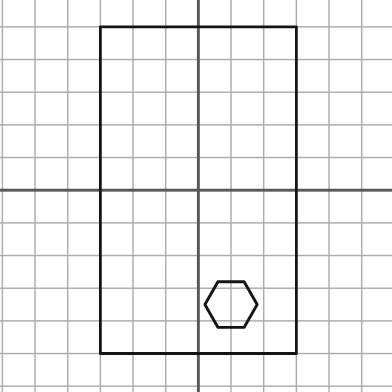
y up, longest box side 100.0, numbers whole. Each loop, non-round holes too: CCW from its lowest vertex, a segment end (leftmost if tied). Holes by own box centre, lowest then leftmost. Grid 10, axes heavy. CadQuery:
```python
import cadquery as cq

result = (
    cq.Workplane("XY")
    .moveTo(-30.0, -50.0)
    .lineTo(30.0, -50.0)
    .lineTo(30.0, 50.0)
    .lineTo(-30.0, 50.0)
    .close()
    .moveTo(6.0, -42.0)
    .lineTo(14.0, -42.0)
    .lineTo(18.0, -35.0)
    .lineTo(14.0, -28.0)
    .lineTo(6.0, -28.0)
    .lineTo(2.0, -35.0)
    .close()
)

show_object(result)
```